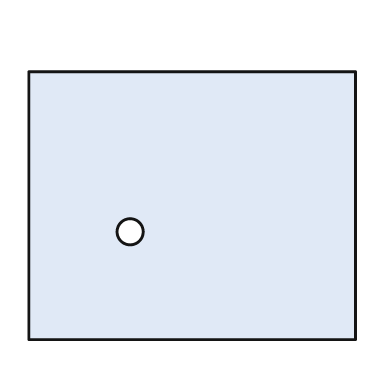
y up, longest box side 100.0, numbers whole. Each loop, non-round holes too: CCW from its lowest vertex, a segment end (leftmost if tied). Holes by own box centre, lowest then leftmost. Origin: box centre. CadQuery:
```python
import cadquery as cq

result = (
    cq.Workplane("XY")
    .moveTo(-50.0, -41.0)
    .lineTo(50.0, -41.0)
    .lineTo(50.0, 41.0)
    .lineTo(-50.0, 41.0)
    .close()
    .moveTo(-19.0, -8.0)
    .circle(4.0)
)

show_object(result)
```